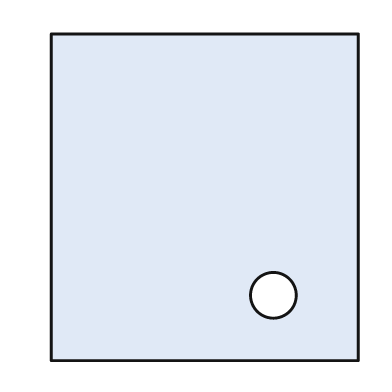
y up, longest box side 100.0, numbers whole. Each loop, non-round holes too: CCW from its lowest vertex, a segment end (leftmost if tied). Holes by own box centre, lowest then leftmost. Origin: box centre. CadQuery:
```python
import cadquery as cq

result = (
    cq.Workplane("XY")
    .moveTo(-47.0, -50.0)
    .lineTo(47.0, -50.0)
    .lineTo(47.0, 50.0)
    .lineTo(-47.0, 50.0)
    .close()
    .moveTo(21.0, -30.0)
    .circle(7.0)
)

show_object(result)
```